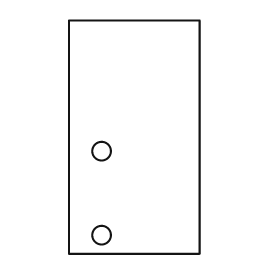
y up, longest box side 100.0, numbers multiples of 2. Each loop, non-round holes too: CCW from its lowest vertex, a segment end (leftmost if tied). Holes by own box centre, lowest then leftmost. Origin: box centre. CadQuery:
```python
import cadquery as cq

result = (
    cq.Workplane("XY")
    .moveTo(-28.0, -50.0)
    .lineTo(28.0, -50.0)
    .lineTo(28.0, 50.0)
    .lineTo(-28.0, 50.0)
    .close()
    .moveTo(-14.0, -42.0)
    .circle(4.0)
    .moveTo(-14.0, -6.0)
    .circle(4.0)
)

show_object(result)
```